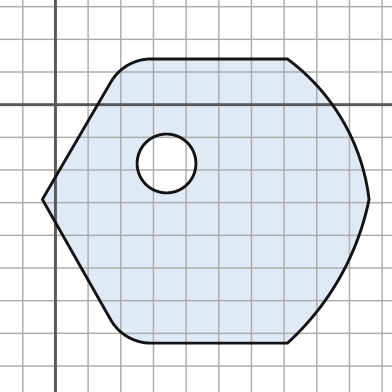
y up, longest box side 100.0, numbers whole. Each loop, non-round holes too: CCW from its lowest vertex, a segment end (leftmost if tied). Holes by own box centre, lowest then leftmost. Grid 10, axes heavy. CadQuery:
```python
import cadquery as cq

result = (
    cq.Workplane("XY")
    .moveTo(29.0, -73.0)
    .lineTo(71.0, -73.0)
    .threePointArc((87.0, -53.0), (96.0, -29.0))
    .threePointArc((88.0, -5.0), (71.0, 14.0))
    .lineTo(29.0, 14.0)
    .threePointArc((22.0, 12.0), (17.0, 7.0))
    .lineTo(-4.0, -29.0)
    .lineTo(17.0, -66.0)
    .threePointArc((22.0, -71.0), (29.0, -73.0))
    .close()
    .moveTo(34.0, -18.0)
    .circle(9.0)
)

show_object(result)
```